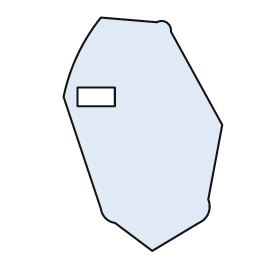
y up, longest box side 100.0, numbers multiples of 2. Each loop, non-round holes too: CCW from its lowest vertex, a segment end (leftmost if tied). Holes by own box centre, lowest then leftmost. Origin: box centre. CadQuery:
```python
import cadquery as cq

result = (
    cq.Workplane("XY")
    .moveTo(4.0, -50.0)
    .lineTo(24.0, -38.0)
    .threePointArc((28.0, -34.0), (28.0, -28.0))
    .lineTo(34.0, 4.0)
    .lineTo(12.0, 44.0)
    .threePointArc((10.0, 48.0), (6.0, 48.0))
    .lineTo(-18.0, 50.0)
    .threePointArc((-28.0, 34.0), (-34.0, 16.0))
    .lineTo(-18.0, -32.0)
    .threePointArc((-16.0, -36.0), (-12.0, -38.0))
    .close()
    .moveTo(-28.0, 12.0)
    .lineTo(-12.0, 12.0)
    .lineTo(-12.0, 20.0)
    .lineTo(-28.0, 20.0)
    .close()
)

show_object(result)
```